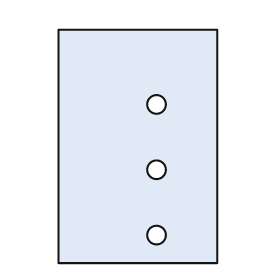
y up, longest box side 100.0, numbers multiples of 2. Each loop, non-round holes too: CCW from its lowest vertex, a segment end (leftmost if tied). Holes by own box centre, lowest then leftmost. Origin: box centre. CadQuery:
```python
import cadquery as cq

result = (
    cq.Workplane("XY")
    .moveTo(-34.0, -50.0)
    .lineTo(34.0, -50.0)
    .lineTo(34.0, 50.0)
    .lineTo(-34.0, 50.0)
    .close()
    .moveTo(8.0, -38.0)
    .circle(4.0)
    .moveTo(8.0, -10.0)
    .circle(4.0)
    .moveTo(8.0, 18.0)
    .circle(4.0)
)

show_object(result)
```